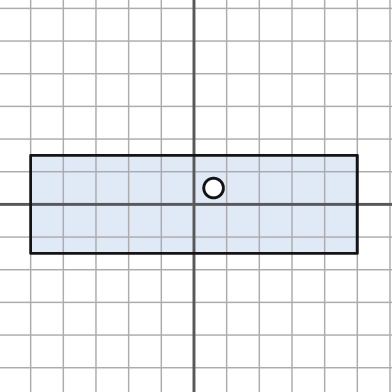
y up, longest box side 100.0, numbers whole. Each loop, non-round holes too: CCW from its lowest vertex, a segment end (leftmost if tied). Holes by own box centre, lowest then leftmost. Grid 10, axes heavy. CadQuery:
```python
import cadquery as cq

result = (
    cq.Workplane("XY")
    .moveTo(-50.0, -15.0)
    .lineTo(50.0, -15.0)
    .lineTo(50.0, 15.0)
    .lineTo(-50.0, 15.0)
    .close()
    .moveTo(6.0, 5.0)
    .circle(3.0)
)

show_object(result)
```